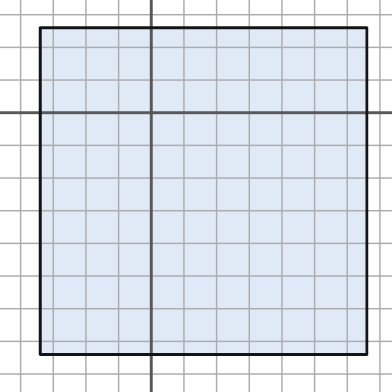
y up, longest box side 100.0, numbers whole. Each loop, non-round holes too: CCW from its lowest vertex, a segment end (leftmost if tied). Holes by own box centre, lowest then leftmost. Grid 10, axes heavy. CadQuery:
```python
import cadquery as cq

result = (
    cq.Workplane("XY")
    .moveTo(-34.0, -74.0)
    .lineTo(66.0, -74.0)
    .lineTo(66.0, 26.0)
    .lineTo(-34.0, 26.0)
    .close()
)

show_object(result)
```